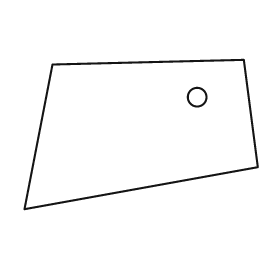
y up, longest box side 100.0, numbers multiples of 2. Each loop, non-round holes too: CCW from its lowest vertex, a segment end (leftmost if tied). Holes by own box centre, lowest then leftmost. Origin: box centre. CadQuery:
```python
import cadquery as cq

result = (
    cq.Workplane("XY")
    .moveTo(-50.0, -32.0)
    .lineTo(50.0, -14.0)
    .lineTo(44.0, 32.0)
    .lineTo(-38.0, 30.0)
    .close()
    .moveTo(24.0, 16.0)
    .circle(4.0)
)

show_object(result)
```